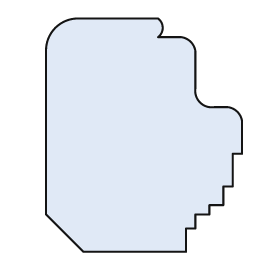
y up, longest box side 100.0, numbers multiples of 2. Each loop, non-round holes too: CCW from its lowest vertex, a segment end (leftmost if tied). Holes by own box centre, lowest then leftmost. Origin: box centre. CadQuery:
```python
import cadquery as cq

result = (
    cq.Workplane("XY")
    .moveTo(-26.0, -50.0)
    .lineTo(18.0, -50.0)
    .lineTo(18.0, -40.0)
    .lineTo(22.0, -40.0)
    .lineTo(22.0, -34.0)
    .lineTo(28.0, -34.0)
    .lineTo(28.0, -30.0)
    .lineTo(34.0, -30.0)
    .lineTo(34.0, -22.0)
    .lineTo(38.0, -22.0)
    .lineTo(38.0, -8.0)
    .lineTo(42.0, -8.0)
    .lineTo(42.0, 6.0)
    .threePointArc((40.0, 10.0), (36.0, 12.0))
    .lineTo(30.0, 12.0)
    .threePointArc((24.0, 14.0), (22.0, 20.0))
    .lineTo(22.0, 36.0)
    .threePointArc((20.0, 40.0), (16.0, 42.0))
    .lineTo(6.0, 42.0)
    .threePointArc((8.0, 46.0), (6.0, 50.0))
    .lineTo(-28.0, 50.0)
    .threePointArc((-38.0, 46.0), (-42.0, 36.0))
    .lineTo(-42.0, -34.0)
    .close()
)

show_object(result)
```